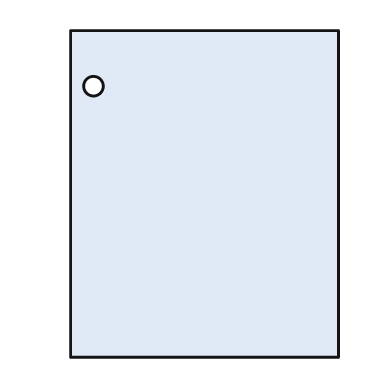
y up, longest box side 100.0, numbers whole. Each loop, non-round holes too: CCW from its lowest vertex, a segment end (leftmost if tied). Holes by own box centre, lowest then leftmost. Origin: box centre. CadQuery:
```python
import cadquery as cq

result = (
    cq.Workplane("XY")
    .moveTo(-41.0, -50.0)
    .lineTo(41.0, -50.0)
    .lineTo(41.0, 50.0)
    .lineTo(-41.0, 50.0)
    .close()
    .moveTo(-34.0, 33.0)
    .circle(3.0)
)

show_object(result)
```